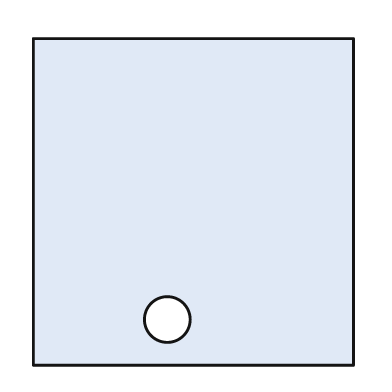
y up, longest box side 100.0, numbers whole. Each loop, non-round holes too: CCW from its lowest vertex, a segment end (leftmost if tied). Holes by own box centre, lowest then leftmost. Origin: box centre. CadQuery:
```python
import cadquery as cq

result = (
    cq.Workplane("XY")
    .moveTo(-49.0, -50.0)
    .lineTo(49.0, -50.0)
    .lineTo(49.0, 50.0)
    .lineTo(-49.0, 50.0)
    .close()
    .moveTo(-8.0, -36.0)
    .circle(7.0)
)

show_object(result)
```